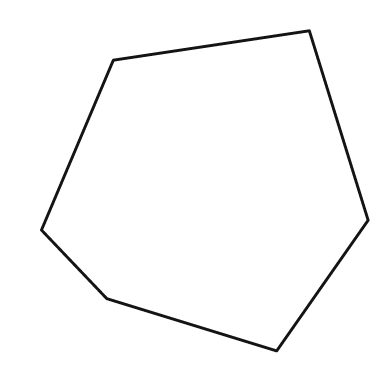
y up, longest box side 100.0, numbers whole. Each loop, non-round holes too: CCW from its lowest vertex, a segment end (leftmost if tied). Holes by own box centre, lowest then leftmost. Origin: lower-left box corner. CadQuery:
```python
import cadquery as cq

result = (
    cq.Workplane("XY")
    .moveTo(72.0, 0.0)
    .lineTo(100.0, 40.0)
    .lineTo(82.0, 98.0)
    .lineTo(22.0, 89.0)
    .lineTo(0.0, 37.0)
    .lineTo(20.0, 16.0)
    .close()
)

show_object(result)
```